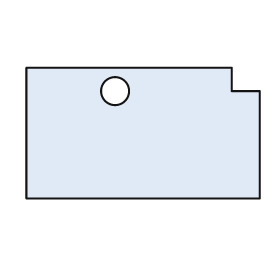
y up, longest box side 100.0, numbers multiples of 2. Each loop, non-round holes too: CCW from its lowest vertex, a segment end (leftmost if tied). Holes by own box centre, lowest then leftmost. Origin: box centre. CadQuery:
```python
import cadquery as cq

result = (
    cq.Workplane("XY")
    .moveTo(-50.0, -28.0)
    .lineTo(50.0, -28.0)
    .lineTo(50.0, 18.0)
    .lineTo(38.0, 18.0)
    .lineTo(38.0, 28.0)
    .lineTo(-50.0, 28.0)
    .close()
    .moveTo(-12.0, 18.0)
    .circle(6.0)
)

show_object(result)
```